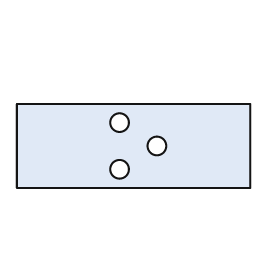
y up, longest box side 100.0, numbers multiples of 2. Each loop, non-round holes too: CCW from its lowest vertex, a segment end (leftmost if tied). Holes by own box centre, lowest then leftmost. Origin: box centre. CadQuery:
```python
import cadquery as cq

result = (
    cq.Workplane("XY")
    .moveTo(-50.0, -18.0)
    .lineTo(50.0, -18.0)
    .lineTo(50.0, 18.0)
    .lineTo(-50.0, 18.0)
    .close()
    .moveTo(-6.0, -10.0)
    .circle(4.0)
    .moveTo(10.0, 0.0)
    .circle(4.0)
    .moveTo(-6.0, 10.0)
    .circle(4.0)
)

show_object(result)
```